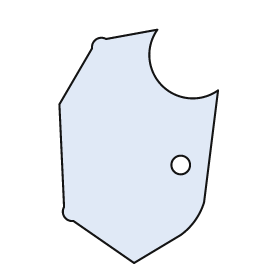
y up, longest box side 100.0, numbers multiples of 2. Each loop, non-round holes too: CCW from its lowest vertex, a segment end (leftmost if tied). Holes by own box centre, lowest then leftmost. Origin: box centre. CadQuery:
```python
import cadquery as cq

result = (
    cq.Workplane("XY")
    .moveTo(-2.0, -50.0)
    .lineTo(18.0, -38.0)
    .threePointArc((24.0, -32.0), (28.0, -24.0))
    .lineTo(34.0, 24.0)
    .threePointArc((10.0, 26.0), (8.0, 50.0))
    .lineTo(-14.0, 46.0)
    .threePointArc((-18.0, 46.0), (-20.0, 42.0))
    .lineTo(-34.0, 18.0)
    .lineTo(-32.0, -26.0)
    .threePointArc((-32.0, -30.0), (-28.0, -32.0))
    .close()
    .moveTo(18.0, -8.0)
    .circle(4.0)
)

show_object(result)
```